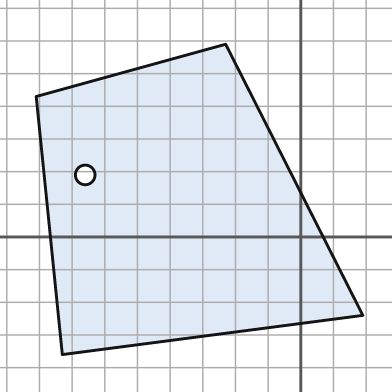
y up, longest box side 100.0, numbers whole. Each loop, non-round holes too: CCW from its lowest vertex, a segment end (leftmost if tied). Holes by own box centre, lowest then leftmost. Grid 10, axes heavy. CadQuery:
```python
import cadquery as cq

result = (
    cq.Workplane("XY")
    .moveTo(-73.0, -36.0)
    .lineTo(19.0, -24.0)
    .lineTo(-23.0, 59.0)
    .lineTo(-81.0, 43.0)
    .close()
    .moveTo(-66.0, 19.0)
    .circle(3.0)
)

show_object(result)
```